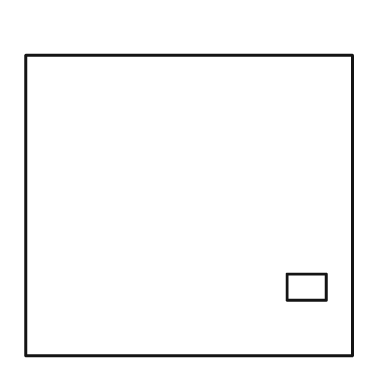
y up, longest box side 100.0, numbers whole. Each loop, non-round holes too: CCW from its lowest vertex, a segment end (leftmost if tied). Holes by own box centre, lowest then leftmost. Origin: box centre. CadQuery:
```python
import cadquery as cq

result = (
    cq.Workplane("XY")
    .moveTo(-50.0, -46.0)
    .lineTo(50.0, -46.0)
    .lineTo(50.0, 46.0)
    .lineTo(-50.0, 46.0)
    .close()
    .moveTo(30.0, -29.0)
    .lineTo(42.0, -29.0)
    .lineTo(42.0, -21.0)
    .lineTo(30.0, -21.0)
    .close()
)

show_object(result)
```